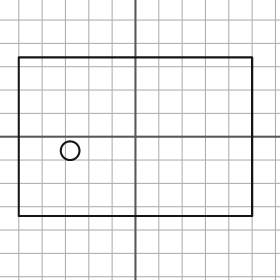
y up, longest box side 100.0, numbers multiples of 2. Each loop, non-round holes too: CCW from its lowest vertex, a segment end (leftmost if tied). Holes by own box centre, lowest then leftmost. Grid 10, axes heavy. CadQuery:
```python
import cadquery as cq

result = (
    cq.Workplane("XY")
    .moveTo(-50.0, -34.0)
    .lineTo(50.0, -34.0)
    .lineTo(50.0, 34.0)
    .lineTo(-50.0, 34.0)
    .close()
    .moveTo(-28.0, -6.0)
    .circle(4.0)
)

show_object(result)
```